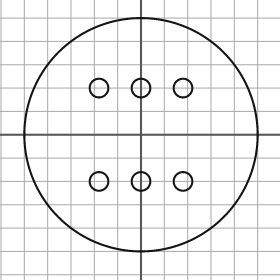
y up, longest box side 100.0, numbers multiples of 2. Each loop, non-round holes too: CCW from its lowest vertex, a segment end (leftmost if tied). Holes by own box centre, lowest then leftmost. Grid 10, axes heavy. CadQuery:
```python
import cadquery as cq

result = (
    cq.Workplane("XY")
    .moveTo(0.0, 0.0)
    .circle(50.0)
    .moveTo(-18.0, -20.0)
    .circle(4.0)
    .moveTo(0.0, -20.0)
    .circle(4.0)
    .moveTo(18.0, -20.0)
    .circle(4.0)
    .moveTo(-18.0, 20.0)
    .circle(4.0)
    .moveTo(0.0, 20.0)
    .circle(4.0)
    .moveTo(18.0, 20.0)
    .circle(4.0)
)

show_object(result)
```